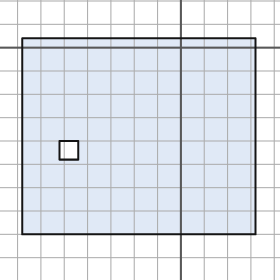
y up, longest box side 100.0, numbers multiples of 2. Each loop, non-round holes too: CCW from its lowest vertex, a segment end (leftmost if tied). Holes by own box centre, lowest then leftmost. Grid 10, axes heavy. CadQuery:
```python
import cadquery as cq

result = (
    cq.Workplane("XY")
    .moveTo(-68.0, -80.0)
    .lineTo(32.0, -80.0)
    .lineTo(32.0, 4.0)
    .lineTo(-68.0, 4.0)
    .close()
    .moveTo(-52.0, -48.0)
    .lineTo(-44.0, -48.0)
    .lineTo(-44.0, -40.0)
    .lineTo(-52.0, -40.0)
    .close()
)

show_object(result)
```